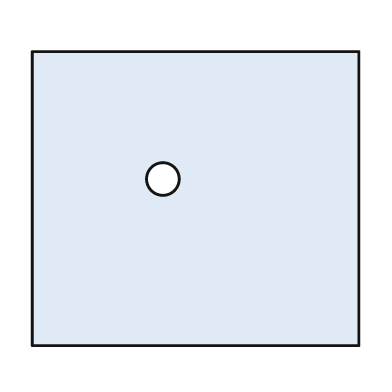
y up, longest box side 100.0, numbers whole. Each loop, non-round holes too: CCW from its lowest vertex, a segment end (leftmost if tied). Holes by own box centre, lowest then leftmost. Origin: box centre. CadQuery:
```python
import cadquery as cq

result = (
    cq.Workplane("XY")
    .moveTo(-50.0, -45.0)
    .lineTo(50.0, -45.0)
    .lineTo(50.0, 45.0)
    .lineTo(-50.0, 45.0)
    .close()
    .moveTo(-10.0, 6.0)
    .circle(5.0)
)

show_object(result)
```